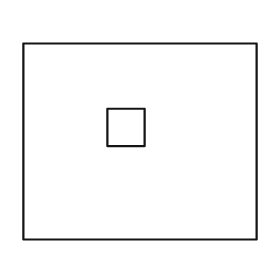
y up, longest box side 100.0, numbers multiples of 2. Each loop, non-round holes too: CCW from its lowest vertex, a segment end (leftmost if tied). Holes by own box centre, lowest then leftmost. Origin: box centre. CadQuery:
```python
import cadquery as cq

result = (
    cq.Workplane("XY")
    .moveTo(-50.0, -42.0)
    .lineTo(50.0, -42.0)
    .lineTo(50.0, 42.0)
    .lineTo(-50.0, 42.0)
    .close()
    .moveTo(-14.0, -2.0)
    .lineTo(2.0, -2.0)
    .lineTo(2.0, 14.0)
    .lineTo(-14.0, 14.0)
    .close()
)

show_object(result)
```